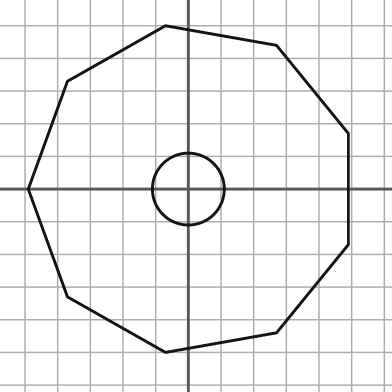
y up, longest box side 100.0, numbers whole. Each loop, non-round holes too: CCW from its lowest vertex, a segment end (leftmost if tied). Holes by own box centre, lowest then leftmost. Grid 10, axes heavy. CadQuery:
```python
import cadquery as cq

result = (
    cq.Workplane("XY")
    .moveTo(-7.0, -50.0)
    .lineTo(27.0, -44.0)
    .lineTo(49.0, -17.0)
    .lineTo(49.0, 17.0)
    .lineTo(27.0, 44.0)
    .lineTo(-7.0, 50.0)
    .lineTo(-37.0, 33.0)
    .lineTo(-49.0, 0.0)
    .lineTo(-37.0, -33.0)
    .close()
    .moveTo(0.0, 0.0)
    .circle(11.0)
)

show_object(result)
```